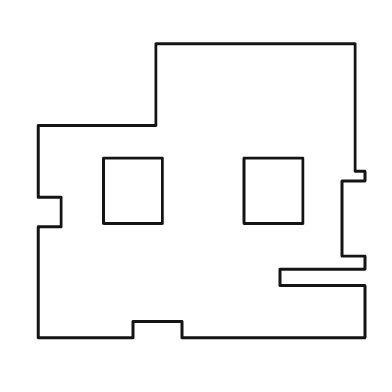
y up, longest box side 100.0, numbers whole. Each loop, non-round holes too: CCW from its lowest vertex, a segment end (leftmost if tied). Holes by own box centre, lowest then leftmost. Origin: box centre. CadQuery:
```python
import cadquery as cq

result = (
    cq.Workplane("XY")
    .moveTo(-50.0, -45.0)
    .lineTo(-21.0, -45.0)
    .lineTo(-21.0, -40.0)
    .lineTo(-6.0, -40.0)
    .lineTo(-6.0, -45.0)
    .lineTo(50.0, -45.0)
    .lineTo(50.0, -29.0)
    .lineTo(24.0, -29.0)
    .lineTo(24.0, -24.0)
    .lineTo(50.0, -24.0)
    .lineTo(50.0, -20.0)
    .lineTo(43.0, -20.0)
    .lineTo(43.0, 3.0)
    .lineTo(50.0, 3.0)
    .lineTo(50.0, 6.0)
    .lineTo(47.0, 6.0)
    .lineTo(47.0, 45.0)
    .lineTo(-14.0, 45.0)
    .lineTo(-14.0, 20.0)
    .lineTo(-50.0, 20.0)
    .lineTo(-50.0, -2.0)
    .lineTo(-43.0, -2.0)
    .lineTo(-43.0, -11.0)
    .lineTo(-50.0, -11.0)
    .close()
    .moveTo(-30.0, -10.0)
    .lineTo(-12.0, -10.0)
    .lineTo(-12.0, 10.0)
    .lineTo(-30.0, 10.0)
    .close()
    .moveTo(13.0, -10.0)
    .lineTo(31.0, -10.0)
    .lineTo(31.0, 10.0)
    .lineTo(13.0, 10.0)
    .close()
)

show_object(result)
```